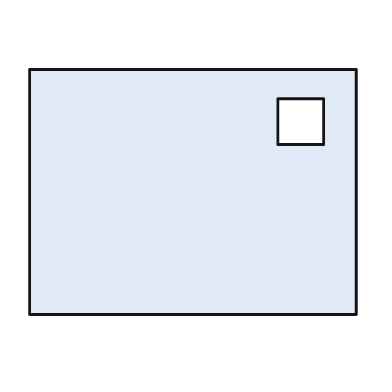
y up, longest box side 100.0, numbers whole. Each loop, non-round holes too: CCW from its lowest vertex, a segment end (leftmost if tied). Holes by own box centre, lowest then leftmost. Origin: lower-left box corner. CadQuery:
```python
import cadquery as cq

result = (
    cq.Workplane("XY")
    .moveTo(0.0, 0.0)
    .lineTo(100.0, 0.0)
    .lineTo(100.0, 75.0)
    .lineTo(0.0, 75.0)
    .close()
    .moveTo(76.0, 52.0)
    .lineTo(90.0, 52.0)
    .lineTo(90.0, 66.0)
    .lineTo(76.0, 66.0)
    .close()
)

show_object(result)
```